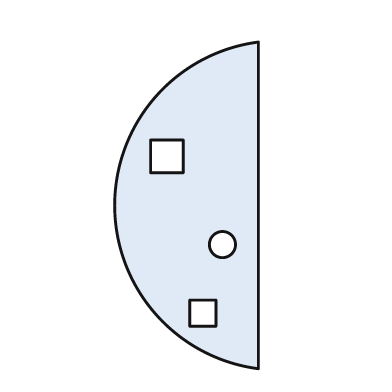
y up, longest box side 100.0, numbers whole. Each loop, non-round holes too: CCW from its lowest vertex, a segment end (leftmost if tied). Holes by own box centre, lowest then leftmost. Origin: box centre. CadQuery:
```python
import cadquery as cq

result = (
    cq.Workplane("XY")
    .moveTo(22.0, -50.0)
    .lineTo(22.0, 50.0)
    .threePointArc((-22.0, 0.0), (22.0, -50.0))
    .close()
    .moveTo(1.0, -37.0)
    .lineTo(9.0, -37.0)
    .lineTo(9.0, -29.0)
    .lineTo(1.0, -29.0)
    .close()
    .moveTo(11.0, -12.0)
    .circle(4.0)
    .moveTo(-11.0, 10.0)
    .lineTo(-1.0, 10.0)
    .lineTo(-1.0, 20.0)
    .lineTo(-11.0, 20.0)
    .close()
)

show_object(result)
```